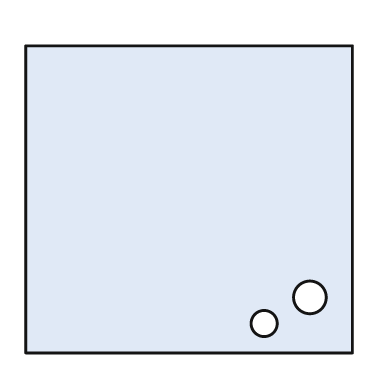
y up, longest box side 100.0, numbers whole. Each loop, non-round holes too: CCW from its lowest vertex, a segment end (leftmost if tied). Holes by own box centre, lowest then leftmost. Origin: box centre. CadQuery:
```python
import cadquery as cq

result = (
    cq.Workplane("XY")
    .moveTo(-50.0, -47.0)
    .lineTo(50.0, -47.0)
    .lineTo(50.0, 47.0)
    .lineTo(-50.0, 47.0)
    .close()
    .moveTo(23.0, -38.0)
    .circle(4.0)
    .moveTo(37.0, -30.0)
    .circle(5.0)
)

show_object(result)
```